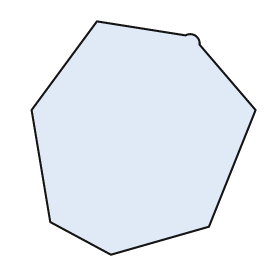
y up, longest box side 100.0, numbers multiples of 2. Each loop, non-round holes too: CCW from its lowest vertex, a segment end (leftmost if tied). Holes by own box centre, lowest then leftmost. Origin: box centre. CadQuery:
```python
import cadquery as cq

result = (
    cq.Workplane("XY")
    .moveTo(-14.0, -50.0)
    .lineTo(28.0, -38.0)
    .lineTo(48.0, 12.0)
    .lineTo(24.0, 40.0)
    .threePointArc((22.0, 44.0), (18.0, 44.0))
    .lineTo(-20.0, 50.0)
    .lineTo(-48.0, 12.0)
    .lineTo(-40.0, -36.0)
    .close()
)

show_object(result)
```